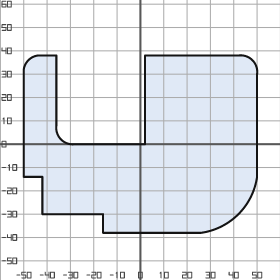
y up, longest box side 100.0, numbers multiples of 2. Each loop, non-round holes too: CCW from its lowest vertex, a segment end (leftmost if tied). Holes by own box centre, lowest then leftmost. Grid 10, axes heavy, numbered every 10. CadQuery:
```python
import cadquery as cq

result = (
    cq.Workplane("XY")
    .moveTo(-16.0, -38.0)
    .lineTo(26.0, -38.0)
    .threePointArc((42.0, -30.0), (50.0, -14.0))
    .lineTo(50.0, 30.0)
    .threePointArc((48.0, 36.0), (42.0, 38.0))
    .lineTo(2.0, 38.0)
    .lineTo(2.0, 0.0)
    .lineTo(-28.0, 0.0)
    .threePointArc((-34.0, 2.0), (-36.0, 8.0))
    .lineTo(-36.0, 38.0)
    .lineTo(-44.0, 38.0)
    .threePointArc((-48.0, 36.0), (-50.0, 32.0))
    .lineTo(-50.0, -14.0)
    .lineTo(-42.0, -14.0)
    .lineTo(-42.0, -30.0)
    .lineTo(-16.0, -30.0)
    .close()
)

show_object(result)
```